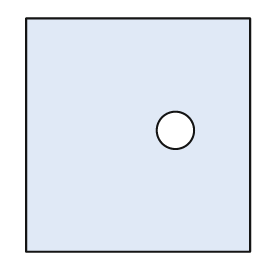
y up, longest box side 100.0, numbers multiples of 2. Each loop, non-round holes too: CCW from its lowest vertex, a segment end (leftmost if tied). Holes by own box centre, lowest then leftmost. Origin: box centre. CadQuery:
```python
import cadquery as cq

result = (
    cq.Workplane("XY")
    .moveTo(-48.0, -50.0)
    .lineTo(48.0, -50.0)
    .lineTo(48.0, 50.0)
    .lineTo(-48.0, 50.0)
    .close()
    .moveTo(16.0, 2.0)
    .circle(8.0)
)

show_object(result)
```